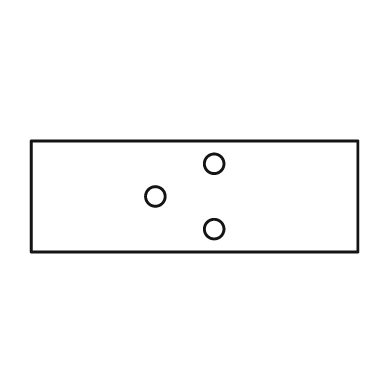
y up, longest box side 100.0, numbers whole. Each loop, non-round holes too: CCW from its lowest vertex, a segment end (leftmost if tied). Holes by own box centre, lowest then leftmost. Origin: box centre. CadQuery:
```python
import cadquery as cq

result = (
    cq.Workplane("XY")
    .moveTo(-50.0, -17.0)
    .lineTo(50.0, -17.0)
    .lineTo(50.0, 17.0)
    .lineTo(-50.0, 17.0)
    .close()
    .moveTo(6.0, -10.0)
    .circle(3.0)
    .moveTo(-12.0, 0.0)
    .circle(3.0)
    .moveTo(6.0, 10.0)
    .circle(3.0)
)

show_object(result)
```